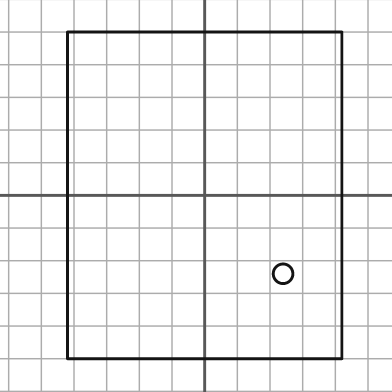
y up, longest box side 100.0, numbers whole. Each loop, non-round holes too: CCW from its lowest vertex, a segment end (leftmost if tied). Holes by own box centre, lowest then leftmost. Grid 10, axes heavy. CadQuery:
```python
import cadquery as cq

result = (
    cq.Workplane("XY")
    .moveTo(-42.0, -50.0)
    .lineTo(42.0, -50.0)
    .lineTo(42.0, 50.0)
    .lineTo(-42.0, 50.0)
    .close()
    .moveTo(24.0, -24.0)
    .circle(3.0)
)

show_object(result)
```